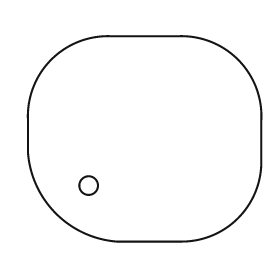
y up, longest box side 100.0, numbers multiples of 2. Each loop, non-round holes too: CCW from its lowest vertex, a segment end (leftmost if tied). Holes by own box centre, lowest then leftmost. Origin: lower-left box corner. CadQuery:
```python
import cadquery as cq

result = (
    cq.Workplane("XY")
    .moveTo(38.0, 0.0)
    .lineTo(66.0, 0.0)
    .threePointArc((90.0, 10.0), (100.0, 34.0))
    .lineTo(100.0, 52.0)
    .threePointArc((90.0, 78.0), (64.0, 88.0))
    .lineTo(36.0, 88.0)
    .threePointArc((10.0, 78.0), (0.0, 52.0))
    .lineTo(0.0, 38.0)
    .threePointArc((12.0, 12.0), (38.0, 0.0))
    .close()
    .moveTo(26.0, 24.0)
    .circle(4.0)
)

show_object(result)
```